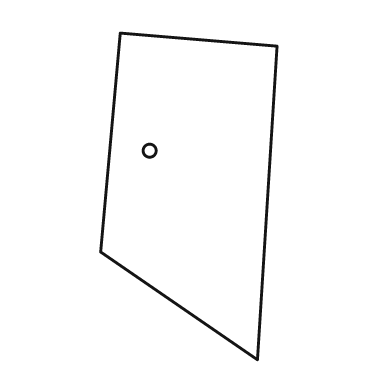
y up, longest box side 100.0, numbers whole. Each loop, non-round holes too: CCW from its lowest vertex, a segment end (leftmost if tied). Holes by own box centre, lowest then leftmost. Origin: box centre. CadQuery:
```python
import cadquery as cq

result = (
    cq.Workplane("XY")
    .moveTo(21.0, -50.0)
    .lineTo(27.0, 46.0)
    .lineTo(-21.0, 50.0)
    .lineTo(-27.0, -17.0)
    .close()
    .moveTo(-12.0, 14.0)
    .circle(2.0)
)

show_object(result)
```